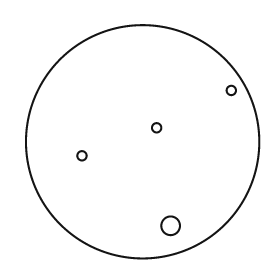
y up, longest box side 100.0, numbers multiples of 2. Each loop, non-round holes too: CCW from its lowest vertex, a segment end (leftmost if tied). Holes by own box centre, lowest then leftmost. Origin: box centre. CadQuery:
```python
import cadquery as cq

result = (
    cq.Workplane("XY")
    .moveTo(0.0, 0.0)
    .circle(50.0)
    .moveTo(12.0, -36.0)
    .circle(4.0)
    .moveTo(-26.0, -6.0)
    .circle(2.0)
    .moveTo(6.0, 6.0)
    .circle(2.0)
    .moveTo(38.0, 22.0)
    .circle(2.0)
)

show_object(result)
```